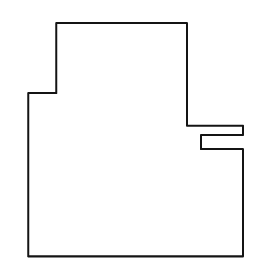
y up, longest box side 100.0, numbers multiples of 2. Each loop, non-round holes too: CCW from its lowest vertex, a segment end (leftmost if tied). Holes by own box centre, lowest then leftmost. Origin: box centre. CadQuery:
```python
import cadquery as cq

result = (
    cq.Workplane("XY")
    .moveTo(-46.0, -50.0)
    .lineTo(46.0, -50.0)
    .lineTo(46.0, -4.0)
    .lineTo(28.0, -4.0)
    .lineTo(28.0, 2.0)
    .lineTo(46.0, 2.0)
    .lineTo(46.0, 6.0)
    .lineTo(22.0, 6.0)
    .lineTo(22.0, 50.0)
    .lineTo(-34.0, 50.0)
    .lineTo(-34.0, 20.0)
    .lineTo(-46.0, 20.0)
    .close()
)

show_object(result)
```